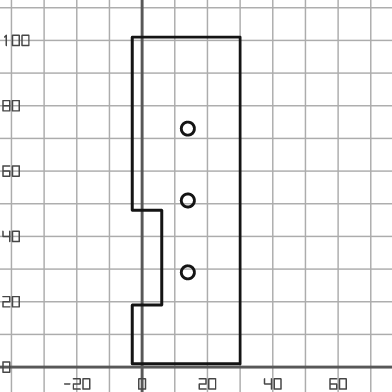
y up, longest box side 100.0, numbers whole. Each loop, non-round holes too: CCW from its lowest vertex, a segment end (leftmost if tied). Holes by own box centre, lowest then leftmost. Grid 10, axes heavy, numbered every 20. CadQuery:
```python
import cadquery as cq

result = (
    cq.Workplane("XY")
    .moveTo(-3.0, 1.0)
    .lineTo(30.0, 1.0)
    .lineTo(30.0, 101.0)
    .lineTo(-3.0, 101.0)
    .lineTo(-3.0, 48.0)
    .lineTo(6.0, 48.0)
    .lineTo(6.0, 19.0)
    .lineTo(-3.0, 19.0)
    .close()
    .moveTo(14.0, 29.0)
    .circle(2.0)
    .moveTo(14.0, 51.0)
    .circle(2.0)
    .moveTo(14.0, 73.0)
    .circle(2.0)
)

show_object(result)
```